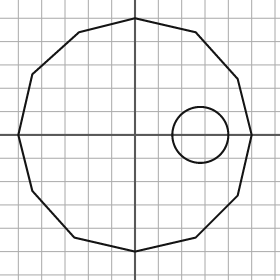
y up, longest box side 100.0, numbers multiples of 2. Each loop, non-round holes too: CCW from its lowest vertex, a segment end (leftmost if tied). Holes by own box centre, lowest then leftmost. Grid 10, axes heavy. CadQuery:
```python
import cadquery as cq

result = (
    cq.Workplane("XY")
    .moveTo(0.0, -50.0)
    .lineTo(26.0, -44.0)
    .lineTo(44.0, -26.0)
    .lineTo(50.0, 0.0)
    .lineTo(44.0, 24.0)
    .lineTo(26.0, 44.0)
    .lineTo(0.0, 50.0)
    .lineTo(-24.0, 44.0)
    .lineTo(-44.0, 26.0)
    .lineTo(-50.0, 0.0)
    .lineTo(-44.0, -24.0)
    .lineTo(-26.0, -44.0)
    .close()
    .moveTo(28.0, 0.0)
    .circle(12.0)
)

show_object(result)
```